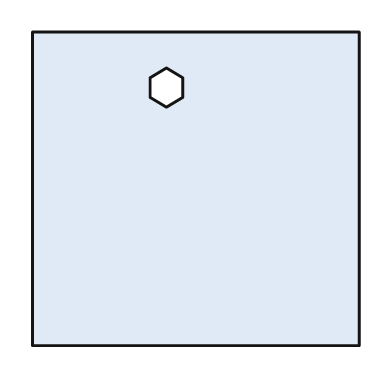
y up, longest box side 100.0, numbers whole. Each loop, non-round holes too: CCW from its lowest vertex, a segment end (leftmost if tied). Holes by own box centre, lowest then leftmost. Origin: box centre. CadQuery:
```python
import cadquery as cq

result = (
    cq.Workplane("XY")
    .moveTo(-50.0, -48.0)
    .lineTo(50.0, -48.0)
    .lineTo(50.0, 48.0)
    .lineTo(-50.0, 48.0)
    .close()
    .moveTo(-9.0, 25.0)
    .lineTo(-4.0, 28.0)
    .lineTo(-4.0, 34.0)
    .lineTo(-9.0, 37.0)
    .lineTo(-14.0, 34.0)
    .lineTo(-14.0, 28.0)
    .close()
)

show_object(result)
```